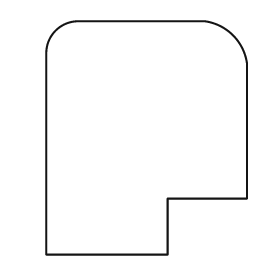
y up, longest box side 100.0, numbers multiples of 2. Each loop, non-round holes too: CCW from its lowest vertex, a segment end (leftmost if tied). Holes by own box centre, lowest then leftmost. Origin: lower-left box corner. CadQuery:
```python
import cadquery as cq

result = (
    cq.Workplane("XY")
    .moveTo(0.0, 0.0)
    .lineTo(52.0, 0.0)
    .lineTo(52.0, 24.0)
    .lineTo(86.0, 24.0)
    .lineTo(86.0, 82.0)
    .threePointArc((80.0, 94.0), (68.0, 100.0))
    .lineTo(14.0, 100.0)
    .threePointArc((4.0, 96.0), (0.0, 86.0))
    .close()
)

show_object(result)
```